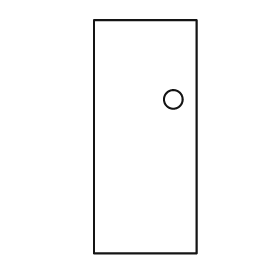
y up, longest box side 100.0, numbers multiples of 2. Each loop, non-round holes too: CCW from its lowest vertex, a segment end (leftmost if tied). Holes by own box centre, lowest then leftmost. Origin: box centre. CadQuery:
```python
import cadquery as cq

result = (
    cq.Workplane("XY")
    .moveTo(-22.0, -50.0)
    .lineTo(22.0, -50.0)
    .lineTo(22.0, 50.0)
    .lineTo(-22.0, 50.0)
    .close()
    .moveTo(12.0, 16.0)
    .circle(4.0)
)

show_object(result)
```